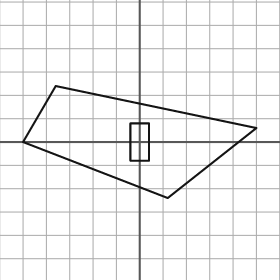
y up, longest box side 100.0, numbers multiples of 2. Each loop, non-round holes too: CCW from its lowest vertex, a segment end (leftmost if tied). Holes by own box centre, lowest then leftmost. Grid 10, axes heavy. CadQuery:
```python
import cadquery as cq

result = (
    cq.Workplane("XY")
    .moveTo(12.0, -24.0)
    .lineTo(50.0, 6.0)
    .lineTo(-36.0, 24.0)
    .lineTo(-50.0, 0.0)
    .close()
    .moveTo(-4.0, -8.0)
    .lineTo(4.0, -8.0)
    .lineTo(4.0, 8.0)
    .lineTo(-4.0, 8.0)
    .close()
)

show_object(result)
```